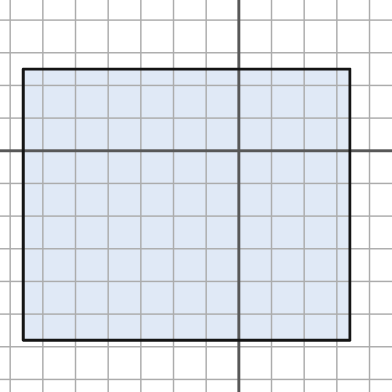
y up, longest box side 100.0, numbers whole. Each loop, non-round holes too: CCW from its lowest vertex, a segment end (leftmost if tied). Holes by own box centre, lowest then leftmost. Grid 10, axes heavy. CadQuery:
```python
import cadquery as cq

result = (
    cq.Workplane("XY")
    .moveTo(-66.0, -58.0)
    .lineTo(34.0, -58.0)
    .lineTo(34.0, 25.0)
    .lineTo(-66.0, 25.0)
    .close()
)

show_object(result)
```